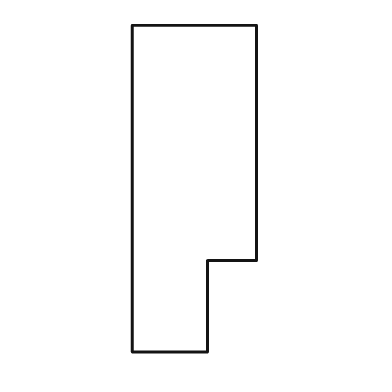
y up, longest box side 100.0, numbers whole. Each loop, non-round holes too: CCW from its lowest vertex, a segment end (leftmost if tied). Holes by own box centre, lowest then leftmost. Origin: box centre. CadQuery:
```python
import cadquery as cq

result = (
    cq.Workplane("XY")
    .moveTo(-19.0, -50.0)
    .lineTo(4.0, -50.0)
    .lineTo(4.0, -22.0)
    .lineTo(19.0, -22.0)
    .lineTo(19.0, 50.0)
    .lineTo(-19.0, 50.0)
    .close()
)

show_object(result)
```